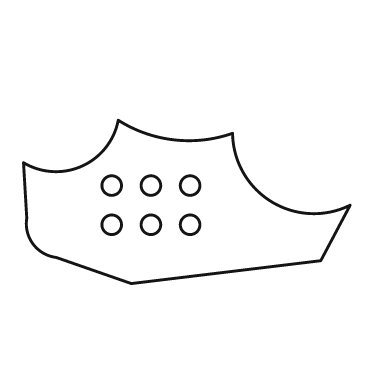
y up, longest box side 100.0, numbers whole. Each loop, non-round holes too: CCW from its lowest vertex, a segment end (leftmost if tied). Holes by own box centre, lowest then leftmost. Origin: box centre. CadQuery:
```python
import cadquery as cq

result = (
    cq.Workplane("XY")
    .moveTo(-17.0, -25.0)
    .lineTo(41.0, -18.0)
    .lineTo(50.0, -1.0)
    .threePointArc((26.0, 0.0), (14.0, 21.0))
    .threePointArc((-4.0, 19.0), (-21.0, 25.0))
    .threePointArc((-32.0, 11.0), (-50.0, 12.0))
    .lineTo(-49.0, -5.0)
    .threePointArc((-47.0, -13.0), (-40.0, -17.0))
    .close()
    .moveTo(-23.0, -7.0)
    .circle(3.0)
    .moveTo(-11.0, -7.0)
    .circle(3.0)
    .moveTo(1.0, -7.0)
    .circle(3.0)
    .moveTo(-23.0, 5.0)
    .circle(3.0)
    .moveTo(-11.0, 5.0)
    .circle(3.0)
    .moveTo(1.0, 5.0)
    .circle(3.0)
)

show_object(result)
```